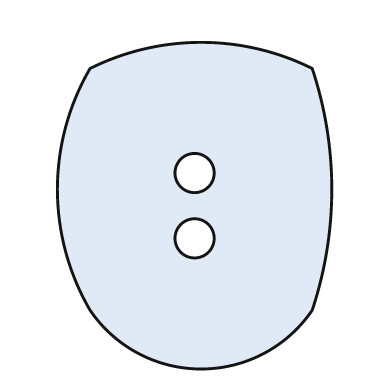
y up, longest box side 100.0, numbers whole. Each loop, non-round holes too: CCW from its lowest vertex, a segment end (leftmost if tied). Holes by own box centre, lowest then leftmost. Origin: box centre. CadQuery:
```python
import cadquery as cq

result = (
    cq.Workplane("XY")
    .moveTo(-32.0, -32.0)
    .threePointArc((2.0, -50.0), (36.0, -32.0))
    .threePointArc((42.0, 5.0), (36.0, 42.0))
    .threePointArc((2.0, 50.0), (-32.0, 42.0))
    .threePointArc((-42.0, 5.0), (-32.0, -32.0))
    .close()
    .moveTo(0.0, -10.0)
    .circle(6.0)
    .moveTo(0.0, 10.0)
    .circle(6.0)
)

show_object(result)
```